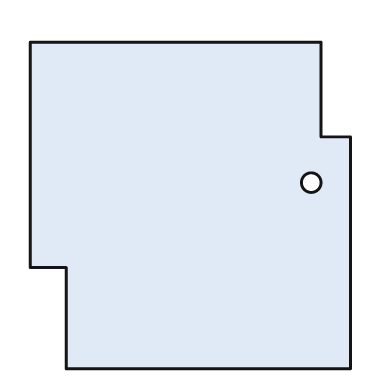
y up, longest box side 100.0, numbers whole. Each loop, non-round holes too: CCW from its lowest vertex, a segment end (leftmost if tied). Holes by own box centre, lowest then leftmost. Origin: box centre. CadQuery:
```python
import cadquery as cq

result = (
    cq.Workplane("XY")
    .moveTo(-38.0, -50.0)
    .lineTo(49.0, -50.0)
    .lineTo(49.0, 21.0)
    .lineTo(40.0, 21.0)
    .lineTo(40.0, 50.0)
    .lineTo(-49.0, 50.0)
    .lineTo(-49.0, -19.0)
    .lineTo(-38.0, -19.0)
    .close()
    .moveTo(37.0, 7.0)
    .circle(3.0)
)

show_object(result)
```